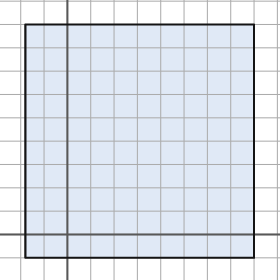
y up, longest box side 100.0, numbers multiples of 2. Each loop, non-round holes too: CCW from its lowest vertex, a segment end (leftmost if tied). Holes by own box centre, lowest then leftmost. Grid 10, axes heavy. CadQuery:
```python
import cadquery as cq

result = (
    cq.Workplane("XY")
    .moveTo(-18.0, -10.0)
    .lineTo(80.0, -10.0)
    .lineTo(80.0, 90.0)
    .lineTo(-18.0, 90.0)
    .close()
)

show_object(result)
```